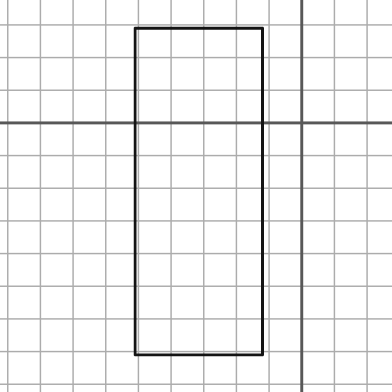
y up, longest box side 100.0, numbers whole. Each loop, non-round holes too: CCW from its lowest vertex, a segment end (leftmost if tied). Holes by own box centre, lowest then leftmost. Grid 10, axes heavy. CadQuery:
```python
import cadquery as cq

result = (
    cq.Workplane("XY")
    .moveTo(-51.0, -71.0)
    .lineTo(-12.0, -71.0)
    .lineTo(-12.0, 29.0)
    .lineTo(-51.0, 29.0)
    .close()
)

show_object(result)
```